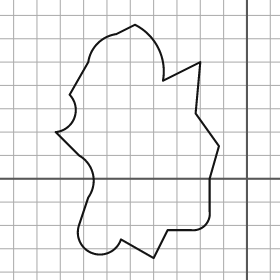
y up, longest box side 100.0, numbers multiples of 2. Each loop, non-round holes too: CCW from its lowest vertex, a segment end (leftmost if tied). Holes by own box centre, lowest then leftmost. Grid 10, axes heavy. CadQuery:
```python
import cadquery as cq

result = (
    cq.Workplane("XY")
    .moveTo(-40.0, -34.0)
    .lineTo(-34.0, -22.0)
    .lineTo(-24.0, -22.0)
    .threePointArc((-18.0, -20.0), (-16.0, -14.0))
    .lineTo(-16.0, 0.0)
    .lineTo(-12.0, 14.0)
    .lineTo(-22.0, 28.0)
    .lineTo(-20.0, 50.0)
    .lineTo(-36.0, 42.0)
    .threePointArc((-38.0, 56.0), (-48.0, 66.0))
    .lineTo(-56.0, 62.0)
    .threePointArc((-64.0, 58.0), (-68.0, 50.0))
    .lineTo(-76.0, 36.0)
    .threePointArc((-74.0, 26.0), (-82.0, 20.0))
    .lineTo(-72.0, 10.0)
    .threePointArc((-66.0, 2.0), (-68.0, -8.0))
    .lineTo(-72.0, -20.0)
    .threePointArc((-66.0, -32.0), (-54.0, -26.0))
    .close()
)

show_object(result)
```